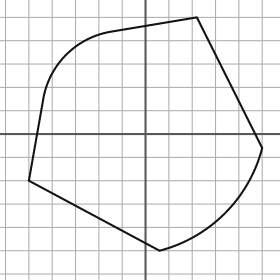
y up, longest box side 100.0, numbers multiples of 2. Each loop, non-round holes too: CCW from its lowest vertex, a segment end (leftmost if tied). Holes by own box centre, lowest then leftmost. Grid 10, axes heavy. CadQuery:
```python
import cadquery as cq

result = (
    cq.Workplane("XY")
    .moveTo(6.0, -50.0)
    .threePointArc((34.0, -34.0), (50.0, -6.0))
    .lineTo(22.0, 50.0)
    .lineTo(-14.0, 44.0)
    .threePointArc((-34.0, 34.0), (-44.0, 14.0))
    .lineTo(-50.0, -20.0)
    .close()
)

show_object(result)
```